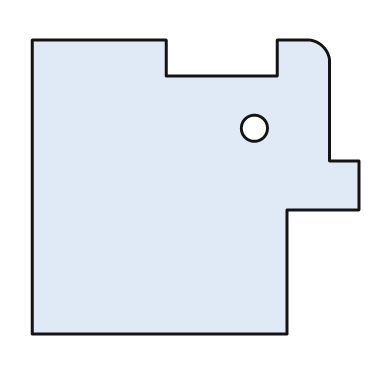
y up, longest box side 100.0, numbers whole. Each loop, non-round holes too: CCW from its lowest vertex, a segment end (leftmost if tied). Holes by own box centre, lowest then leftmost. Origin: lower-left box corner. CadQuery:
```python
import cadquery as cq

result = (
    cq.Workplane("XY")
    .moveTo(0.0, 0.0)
    .lineTo(78.0, 0.0)
    .lineTo(78.0, 38.0)
    .lineTo(100.0, 38.0)
    .lineTo(100.0, 53.0)
    .lineTo(91.0, 53.0)
    .lineTo(91.0, 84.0)
    .threePointArc((89.0, 88.0), (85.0, 90.0))
    .lineTo(75.0, 90.0)
    .lineTo(75.0, 79.0)
    .lineTo(41.0, 79.0)
    .lineTo(41.0, 90.0)
    .lineTo(0.0, 90.0)
    .close()
    .moveTo(68.0, 63.0)
    .circle(4.0)
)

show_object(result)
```